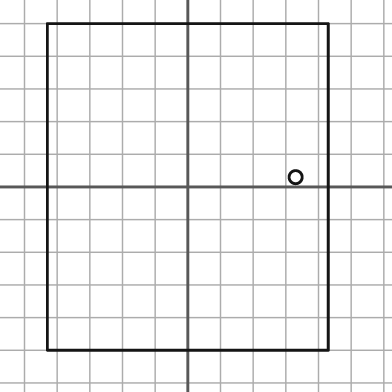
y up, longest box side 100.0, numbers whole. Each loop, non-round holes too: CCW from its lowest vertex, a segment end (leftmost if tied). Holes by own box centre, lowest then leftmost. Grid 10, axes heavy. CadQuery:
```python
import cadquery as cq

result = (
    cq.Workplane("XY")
    .moveTo(-43.0, -50.0)
    .lineTo(43.0, -50.0)
    .lineTo(43.0, 50.0)
    .lineTo(-43.0, 50.0)
    .close()
    .moveTo(33.0, 3.0)
    .circle(2.0)
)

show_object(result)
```